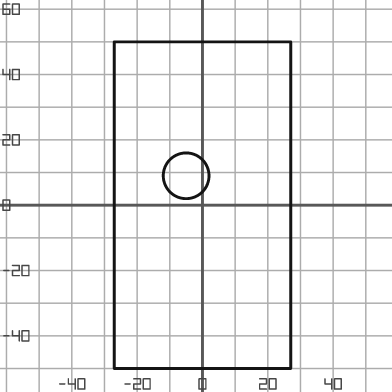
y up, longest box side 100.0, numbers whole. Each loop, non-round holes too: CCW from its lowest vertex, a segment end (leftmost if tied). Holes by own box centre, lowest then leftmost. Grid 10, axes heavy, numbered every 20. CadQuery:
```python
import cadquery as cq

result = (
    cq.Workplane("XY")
    .moveTo(-27.0, -50.0)
    .lineTo(27.0, -50.0)
    .lineTo(27.0, 50.0)
    .lineTo(-27.0, 50.0)
    .close()
    .moveTo(-5.0, 9.0)
    .circle(7.0)
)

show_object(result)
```